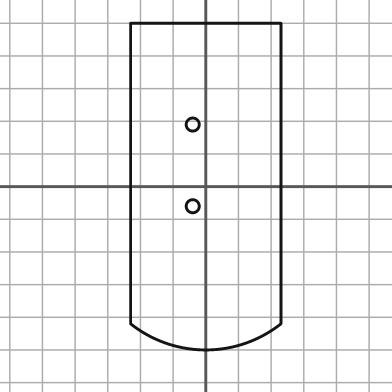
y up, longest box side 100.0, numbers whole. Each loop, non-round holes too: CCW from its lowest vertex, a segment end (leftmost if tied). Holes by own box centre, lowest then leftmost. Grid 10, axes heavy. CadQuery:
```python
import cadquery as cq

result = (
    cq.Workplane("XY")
    .moveTo(-23.0, -42.0)
    .threePointArc((0.0, -50.0), (23.0, -42.0))
    .lineTo(23.0, 50.0)
    .lineTo(-23.0, 50.0)
    .close()
    .moveTo(-4.0, -6.0)
    .circle(2.0)
    .moveTo(-4.0, 19.0)
    .circle(2.0)
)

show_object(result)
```